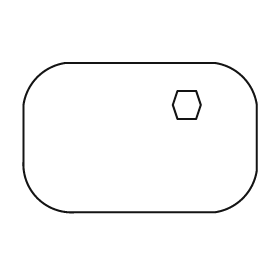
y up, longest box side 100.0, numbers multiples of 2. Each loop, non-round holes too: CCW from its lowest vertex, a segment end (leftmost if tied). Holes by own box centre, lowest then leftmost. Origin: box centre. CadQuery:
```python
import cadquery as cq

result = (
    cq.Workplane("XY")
    .moveTo(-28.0, -32.0)
    .lineTo(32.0, -32.0)
    .threePointArc((44.0, -26.0), (50.0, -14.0))
    .lineTo(50.0, 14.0)
    .threePointArc((44.0, 26.0), (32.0, 32.0))
    .lineTo(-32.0, 32.0)
    .threePointArc((-44.0, 26.0), (-50.0, 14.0))
    .lineTo(-50.0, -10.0)
    .threePointArc((-44.0, -26.0), (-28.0, -32.0))
    .close()
    .moveTo(16.0, 8.0)
    .lineTo(24.0, 8.0)
    .lineTo(26.0, 14.0)
    .lineTo(24.0, 20.0)
    .lineTo(16.0, 20.0)
    .lineTo(14.0, 14.0)
    .close()
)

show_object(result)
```